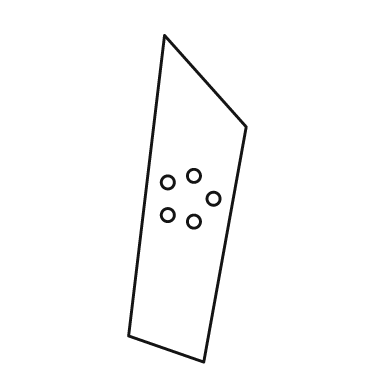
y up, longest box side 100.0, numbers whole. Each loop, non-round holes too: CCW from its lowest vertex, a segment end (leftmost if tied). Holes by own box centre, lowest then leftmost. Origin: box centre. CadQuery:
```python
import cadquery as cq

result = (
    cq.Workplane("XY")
    .moveTo(5.0, -50.0)
    .lineTo(18.0, 22.0)
    .lineTo(-7.0, 50.0)
    .lineTo(-18.0, -42.0)
    .close()
    .moveTo(2.0, -7.0)
    .circle(2.0)
    .moveTo(-6.0, -5.0)
    .circle(2.0)
    .moveTo(8.0, 0.0)
    .circle(2.0)
    .moveTo(-6.0, 5.0)
    .circle(2.0)
    .moveTo(2.0, 7.0)
    .circle(2.0)
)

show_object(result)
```